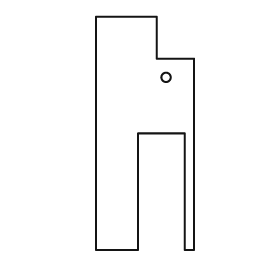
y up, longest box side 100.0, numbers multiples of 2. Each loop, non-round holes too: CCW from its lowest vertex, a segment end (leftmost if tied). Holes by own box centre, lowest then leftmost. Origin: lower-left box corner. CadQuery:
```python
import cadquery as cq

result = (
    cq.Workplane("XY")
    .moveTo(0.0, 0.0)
    .lineTo(18.0, 0.0)
    .lineTo(18.0, 50.0)
    .lineTo(38.0, 50.0)
    .lineTo(38.0, 0.0)
    .lineTo(42.0, 0.0)
    .lineTo(42.0, 82.0)
    .lineTo(26.0, 82.0)
    .lineTo(26.0, 100.0)
    .lineTo(0.0, 100.0)
    .close()
    .moveTo(30.0, 74.0)
    .circle(2.0)
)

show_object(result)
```